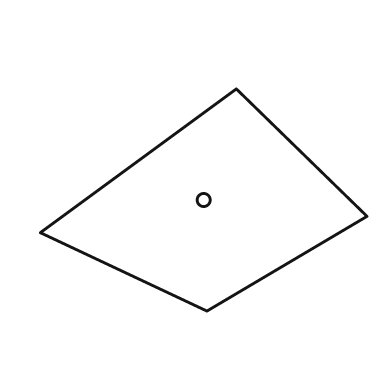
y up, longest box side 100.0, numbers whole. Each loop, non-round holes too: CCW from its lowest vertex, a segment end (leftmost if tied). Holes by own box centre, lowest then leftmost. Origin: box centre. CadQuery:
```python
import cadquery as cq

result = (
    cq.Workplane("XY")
    .moveTo(1.0, -34.0)
    .lineTo(50.0, -5.0)
    .lineTo(10.0, 34.0)
    .lineTo(-50.0, -10.0)
    .close()
    .moveTo(0.0, 0.0)
    .circle(2.0)
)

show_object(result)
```